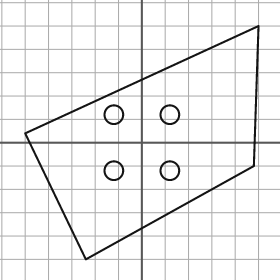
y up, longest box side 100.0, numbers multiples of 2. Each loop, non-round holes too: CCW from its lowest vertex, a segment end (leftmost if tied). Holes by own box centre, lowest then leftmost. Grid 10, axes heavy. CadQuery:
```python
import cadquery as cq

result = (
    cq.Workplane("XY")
    .moveTo(-24.0, -50.0)
    .lineTo(48.0, -10.0)
    .lineTo(50.0, 50.0)
    .lineTo(-50.0, 4.0)
    .close()
    .moveTo(-12.0, -12.0)
    .circle(4.0)
    .moveTo(12.0, -12.0)
    .circle(4.0)
    .moveTo(-12.0, 12.0)
    .circle(4.0)
    .moveTo(12.0, 12.0)
    .circle(4.0)
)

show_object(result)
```